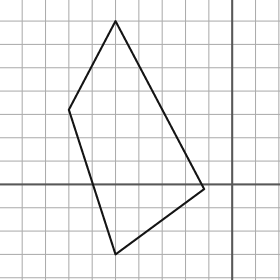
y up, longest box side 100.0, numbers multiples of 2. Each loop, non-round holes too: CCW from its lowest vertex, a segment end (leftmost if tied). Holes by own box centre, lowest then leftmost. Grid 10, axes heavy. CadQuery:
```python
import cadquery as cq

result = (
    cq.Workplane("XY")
    .moveTo(-50.0, -30.0)
    .lineTo(-12.0, -2.0)
    .lineTo(-50.0, 70.0)
    .lineTo(-70.0, 32.0)
    .close()
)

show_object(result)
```